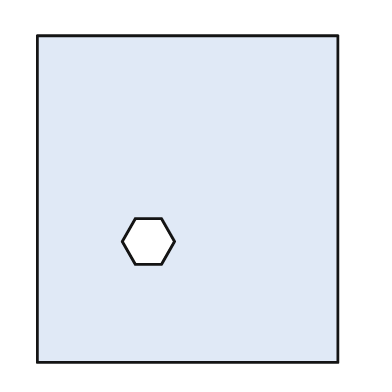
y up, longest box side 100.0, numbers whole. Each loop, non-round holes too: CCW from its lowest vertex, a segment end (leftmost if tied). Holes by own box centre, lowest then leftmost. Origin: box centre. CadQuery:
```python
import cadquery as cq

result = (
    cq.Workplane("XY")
    .moveTo(-46.0, -50.0)
    .lineTo(46.0, -50.0)
    .lineTo(46.0, 50.0)
    .lineTo(-46.0, 50.0)
    .close()
    .moveTo(-16.0, -20.0)
    .lineTo(-8.0, -20.0)
    .lineTo(-4.0, -13.0)
    .lineTo(-8.0, -6.0)
    .lineTo(-16.0, -6.0)
    .lineTo(-20.0, -13.0)
    .close()
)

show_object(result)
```